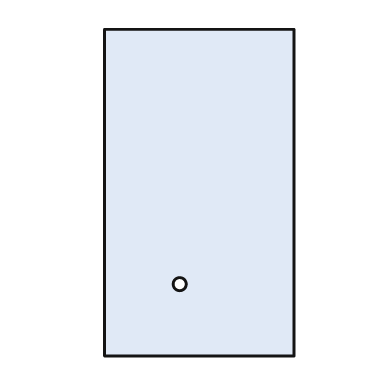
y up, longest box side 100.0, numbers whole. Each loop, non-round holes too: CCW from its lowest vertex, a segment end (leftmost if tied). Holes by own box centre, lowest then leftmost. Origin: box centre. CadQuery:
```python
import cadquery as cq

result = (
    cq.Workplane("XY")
    .moveTo(-29.0, -50.0)
    .lineTo(29.0, -50.0)
    .lineTo(29.0, 50.0)
    .lineTo(-29.0, 50.0)
    .close()
    .moveTo(-6.0, -28.0)
    .circle(2.0)
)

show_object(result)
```